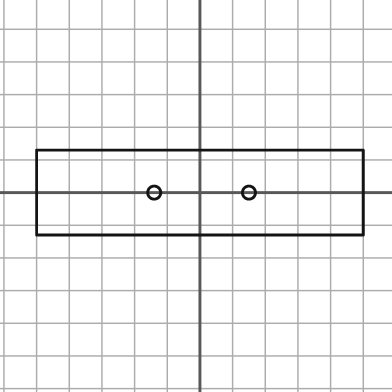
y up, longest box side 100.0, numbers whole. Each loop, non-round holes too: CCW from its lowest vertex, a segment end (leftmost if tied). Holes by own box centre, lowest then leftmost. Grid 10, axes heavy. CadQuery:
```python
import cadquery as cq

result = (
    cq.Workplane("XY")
    .moveTo(-50.0, -13.0)
    .lineTo(50.0, -13.0)
    .lineTo(50.0, 13.0)
    .lineTo(-50.0, 13.0)
    .close()
    .moveTo(-14.0, 0.0)
    .circle(2.0)
    .moveTo(15.0, 0.0)
    .circle(2.0)
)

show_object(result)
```